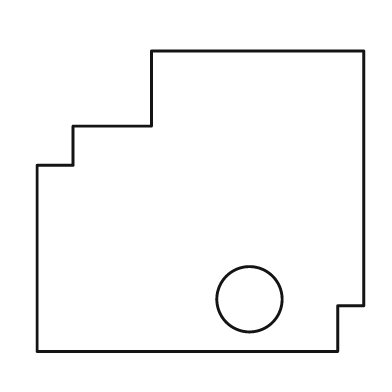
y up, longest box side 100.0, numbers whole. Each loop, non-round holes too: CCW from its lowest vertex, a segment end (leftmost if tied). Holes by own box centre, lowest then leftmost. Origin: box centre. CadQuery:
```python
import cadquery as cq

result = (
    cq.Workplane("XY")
    .moveTo(-50.0, -46.0)
    .lineTo(42.0, -46.0)
    .lineTo(42.0, -32.0)
    .lineTo(50.0, -32.0)
    .lineTo(50.0, 46.0)
    .lineTo(-15.0, 46.0)
    .lineTo(-15.0, 23.0)
    .lineTo(-39.0, 23.0)
    .lineTo(-39.0, 11.0)
    .lineTo(-50.0, 11.0)
    .close()
    .moveTo(15.0, -30.0)
    .circle(10.0)
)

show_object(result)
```